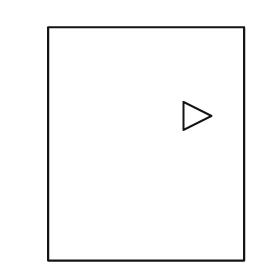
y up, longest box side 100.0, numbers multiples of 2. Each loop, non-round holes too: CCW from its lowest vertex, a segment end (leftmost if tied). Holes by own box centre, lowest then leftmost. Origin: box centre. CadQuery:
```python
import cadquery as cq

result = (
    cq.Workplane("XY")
    .moveTo(-42.0, -50.0)
    .lineTo(42.0, -50.0)
    .lineTo(42.0, 50.0)
    .lineTo(-42.0, 50.0)
    .close()
    .moveTo(16.0, 6.0)
    .lineTo(28.0, 12.0)
    .lineTo(16.0, 18.0)
    .close()
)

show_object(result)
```